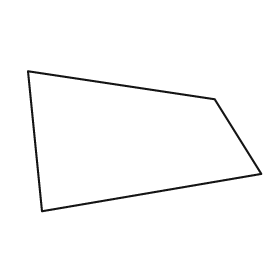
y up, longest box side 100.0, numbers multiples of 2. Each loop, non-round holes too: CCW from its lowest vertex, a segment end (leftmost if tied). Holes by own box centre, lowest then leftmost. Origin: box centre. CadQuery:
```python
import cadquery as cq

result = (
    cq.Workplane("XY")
    .moveTo(-44.0, -30.0)
    .lineTo(50.0, -14.0)
    .lineTo(30.0, 18.0)
    .lineTo(-50.0, 30.0)
    .close()
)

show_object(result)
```